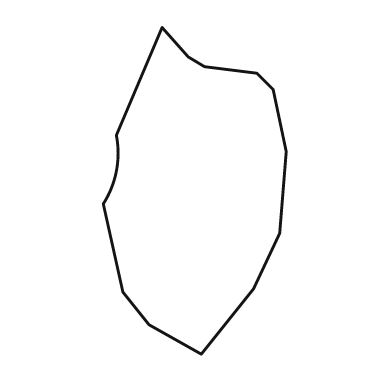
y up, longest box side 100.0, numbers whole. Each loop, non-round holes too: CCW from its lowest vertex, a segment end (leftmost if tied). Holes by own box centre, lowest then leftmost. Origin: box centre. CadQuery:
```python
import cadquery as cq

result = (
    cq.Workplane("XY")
    .moveTo(2.0, -50.0)
    .lineTo(18.0, -30.0)
    .lineTo(26.0, -13.0)
    .lineTo(28.0, 12.0)
    .lineTo(24.0, 31.0)
    .lineTo(19.0, 36.0)
    .lineTo(3.0, 38.0)
    .lineTo(-2.0, 41.0)
    .lineTo(-10.0, 50.0)
    .lineTo(-24.0, 17.0)
    .threePointArc((-24.0, 6.0), (-28.0, -4.0))
    .lineTo(-22.0, -31.0)
    .lineTo(-14.0, -41.0)
    .close()
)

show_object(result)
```